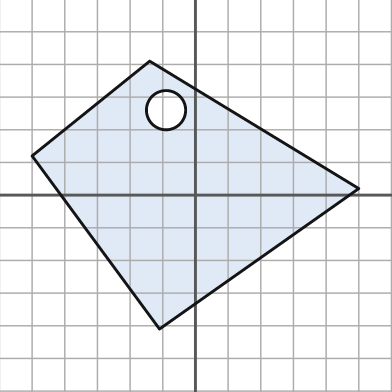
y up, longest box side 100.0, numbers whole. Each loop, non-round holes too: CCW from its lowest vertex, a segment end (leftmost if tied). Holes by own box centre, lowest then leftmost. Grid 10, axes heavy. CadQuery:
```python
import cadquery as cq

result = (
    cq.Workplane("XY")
    .moveTo(-11.0, -41.0)
    .lineTo(50.0, 2.0)
    .lineTo(-14.0, 41.0)
    .lineTo(-50.0, 12.0)
    .close()
    .moveTo(-9.0, 26.0)
    .circle(6.0)
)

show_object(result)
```